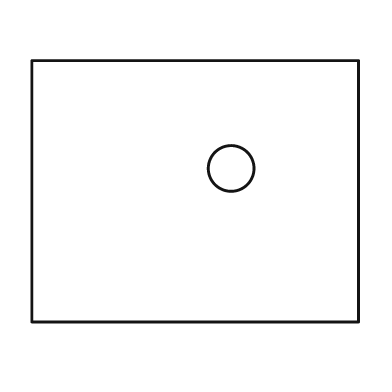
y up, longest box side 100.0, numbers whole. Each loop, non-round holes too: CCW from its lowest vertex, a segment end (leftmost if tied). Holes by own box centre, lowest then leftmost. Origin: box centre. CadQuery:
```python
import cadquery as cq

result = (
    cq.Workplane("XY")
    .moveTo(-50.0, -40.0)
    .lineTo(50.0, -40.0)
    .lineTo(50.0, 40.0)
    .lineTo(-50.0, 40.0)
    .close()
    .moveTo(11.0, 7.0)
    .circle(7.0)
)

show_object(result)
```